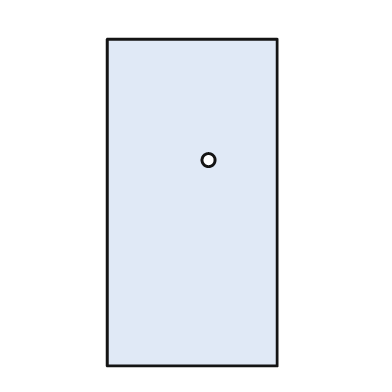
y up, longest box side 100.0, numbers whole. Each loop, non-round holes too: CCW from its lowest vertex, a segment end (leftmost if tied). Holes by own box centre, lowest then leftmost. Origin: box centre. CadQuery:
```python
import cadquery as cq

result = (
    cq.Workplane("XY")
    .moveTo(-26.0, -50.0)
    .lineTo(26.0, -50.0)
    .lineTo(26.0, 50.0)
    .lineTo(-26.0, 50.0)
    .close()
    .moveTo(5.0, 13.0)
    .circle(2.0)
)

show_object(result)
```